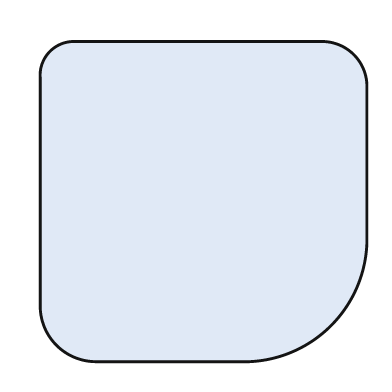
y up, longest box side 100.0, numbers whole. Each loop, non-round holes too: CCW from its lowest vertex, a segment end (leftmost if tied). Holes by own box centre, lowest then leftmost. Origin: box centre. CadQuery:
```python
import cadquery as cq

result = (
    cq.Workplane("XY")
    .moveTo(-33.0, -49.0)
    .lineTo(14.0, -49.0)
    .threePointArc((39.0, -38.0), (50.0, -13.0))
    .lineTo(50.0, 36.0)
    .threePointArc((46.0, 45.0), (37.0, 49.0))
    .lineTo(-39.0, 49.0)
    .threePointArc((-47.0, 46.0), (-50.0, 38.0))
    .lineTo(-50.0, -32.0)
    .threePointArc((-45.0, -44.0), (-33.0, -49.0))
    .close()
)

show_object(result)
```